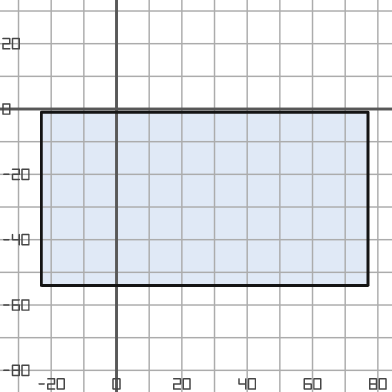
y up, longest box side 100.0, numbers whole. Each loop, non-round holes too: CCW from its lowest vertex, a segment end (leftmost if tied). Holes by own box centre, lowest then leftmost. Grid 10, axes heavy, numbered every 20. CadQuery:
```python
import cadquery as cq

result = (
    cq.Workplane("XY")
    .moveTo(-23.0, -54.0)
    .lineTo(77.0, -54.0)
    .lineTo(77.0, -1.0)
    .lineTo(-23.0, -1.0)
    .close()
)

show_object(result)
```